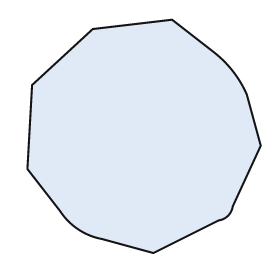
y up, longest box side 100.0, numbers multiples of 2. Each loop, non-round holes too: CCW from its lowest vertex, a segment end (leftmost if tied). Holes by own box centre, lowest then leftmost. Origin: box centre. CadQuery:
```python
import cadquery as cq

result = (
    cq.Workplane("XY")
    .moveTo(4.0, -50.0)
    .lineTo(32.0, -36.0)
    .threePointArc((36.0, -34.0), (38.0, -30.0))
    .lineTo(50.0, -4.0)
    .lineTo(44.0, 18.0)
    .threePointArc((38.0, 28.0), (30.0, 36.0))
    .lineTo(12.0, 50.0)
    .lineTo(-22.0, 46.0)
    .lineTo(-48.0, 22.0)
    .lineTo(-50.0, -14.0)
    .lineTo(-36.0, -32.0)
    .threePointArc((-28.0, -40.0), (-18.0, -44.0))
    .close()
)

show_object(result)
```